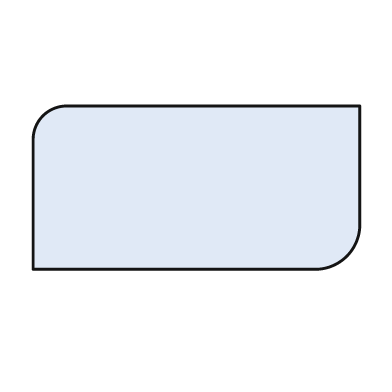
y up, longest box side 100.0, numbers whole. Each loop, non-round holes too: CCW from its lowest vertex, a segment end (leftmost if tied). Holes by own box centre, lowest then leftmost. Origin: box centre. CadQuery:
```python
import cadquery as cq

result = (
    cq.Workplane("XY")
    .moveTo(-50.0, -25.0)
    .lineTo(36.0, -25.0)
    .threePointArc((46.0, -21.0), (50.0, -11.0))
    .lineTo(50.0, 25.0)
    .lineTo(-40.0, 25.0)
    .threePointArc((-47.0, 22.0), (-50.0, 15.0))
    .close()
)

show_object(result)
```